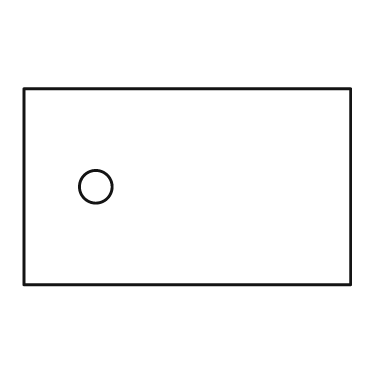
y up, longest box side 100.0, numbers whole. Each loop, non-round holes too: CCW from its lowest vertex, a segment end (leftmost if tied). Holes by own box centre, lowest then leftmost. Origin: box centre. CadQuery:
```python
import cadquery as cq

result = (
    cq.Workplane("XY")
    .moveTo(-50.0, -30.0)
    .lineTo(50.0, -30.0)
    .lineTo(50.0, 30.0)
    .lineTo(-50.0, 30.0)
    .close()
    .moveTo(-28.0, 0.0)
    .circle(5.0)
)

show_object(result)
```